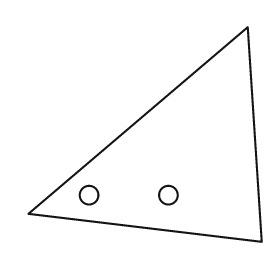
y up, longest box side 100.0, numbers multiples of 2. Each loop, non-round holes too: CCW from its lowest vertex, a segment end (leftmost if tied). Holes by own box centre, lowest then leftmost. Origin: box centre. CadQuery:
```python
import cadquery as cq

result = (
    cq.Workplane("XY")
    .moveTo(50.0, -46.0)
    .lineTo(44.0, 46.0)
    .lineTo(-50.0, -34.0)
    .close()
    .moveTo(-24.0, -26.0)
    .circle(4.0)
    .moveTo(10.0, -26.0)
    .circle(4.0)
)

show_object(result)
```